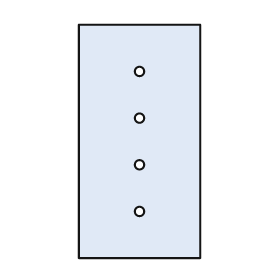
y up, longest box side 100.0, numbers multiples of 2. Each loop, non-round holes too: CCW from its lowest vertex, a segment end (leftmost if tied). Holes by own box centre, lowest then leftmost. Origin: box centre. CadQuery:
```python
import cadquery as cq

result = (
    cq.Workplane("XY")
    .moveTo(-26.0, -50.0)
    .lineTo(26.0, -50.0)
    .lineTo(26.0, 50.0)
    .lineTo(-26.0, 50.0)
    .close()
    .moveTo(0.0, -30.0)
    .circle(2.0)
    .moveTo(0.0, -10.0)
    .circle(2.0)
    .moveTo(0.0, 10.0)
    .circle(2.0)
    .moveTo(0.0, 30.0)
    .circle(2.0)
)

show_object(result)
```